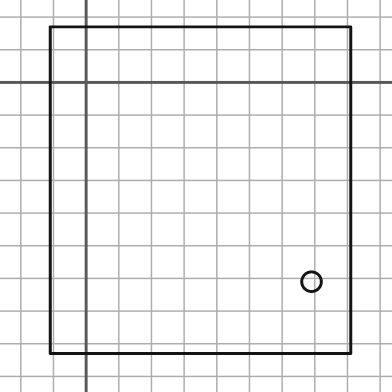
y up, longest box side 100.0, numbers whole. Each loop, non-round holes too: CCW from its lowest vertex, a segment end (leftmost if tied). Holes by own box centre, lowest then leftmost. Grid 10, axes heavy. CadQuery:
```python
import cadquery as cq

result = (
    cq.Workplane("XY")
    .moveTo(-11.0, -83.0)
    .lineTo(81.0, -83.0)
    .lineTo(81.0, 17.0)
    .lineTo(-11.0, 17.0)
    .close()
    .moveTo(69.0, -61.0)
    .circle(3.0)
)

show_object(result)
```